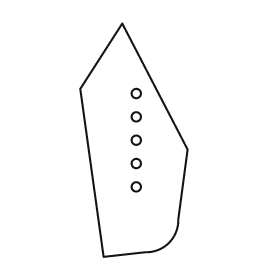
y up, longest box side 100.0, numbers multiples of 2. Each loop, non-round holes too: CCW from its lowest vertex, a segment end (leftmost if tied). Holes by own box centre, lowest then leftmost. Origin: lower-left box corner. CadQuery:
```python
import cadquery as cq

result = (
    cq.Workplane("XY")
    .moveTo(10.0, 0.0)
    .lineTo(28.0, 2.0)
    .threePointArc((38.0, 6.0), (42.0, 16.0))
    .lineTo(46.0, 46.0)
    .lineTo(18.0, 100.0)
    .lineTo(0.0, 72.0)
    .close()
    .moveTo(24.0, 30.0)
    .circle(2.0)
    .moveTo(24.0, 40.0)
    .circle(2.0)
    .moveTo(24.0, 50.0)
    .circle(2.0)
    .moveTo(24.0, 60.0)
    .circle(2.0)
    .moveTo(24.0, 70.0)
    .circle(2.0)
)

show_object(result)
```